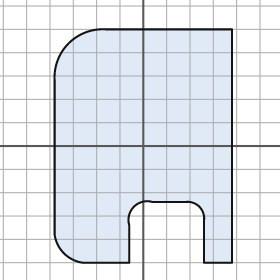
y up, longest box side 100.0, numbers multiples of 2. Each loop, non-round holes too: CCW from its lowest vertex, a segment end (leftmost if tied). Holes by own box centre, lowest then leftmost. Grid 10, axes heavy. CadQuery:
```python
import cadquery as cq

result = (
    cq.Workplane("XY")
    .moveTo(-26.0, -50.0)
    .lineTo(-6.0, -50.0)
    .lineTo(-6.0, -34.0)
    .threePointArc((-4.0, -26.0), (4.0, -24.0))
    .lineTo(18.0, -24.0)
    .threePointArc((24.0, -26.0), (26.0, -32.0))
    .lineTo(26.0, -50.0)
    .lineTo(38.0, -50.0)
    .lineTo(38.0, 50.0)
    .lineTo(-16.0, 50.0)
    .threePointArc((-32.0, 44.0), (-38.0, 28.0))
    .lineTo(-38.0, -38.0)
    .threePointArc((-34.0, -46.0), (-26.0, -50.0))
    .close()
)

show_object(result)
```